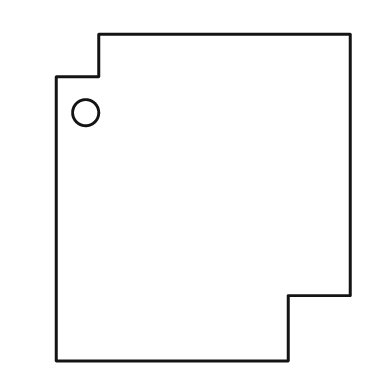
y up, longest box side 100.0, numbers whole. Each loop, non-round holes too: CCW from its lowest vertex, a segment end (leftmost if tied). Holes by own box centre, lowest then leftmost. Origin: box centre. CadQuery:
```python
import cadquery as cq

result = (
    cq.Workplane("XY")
    .moveTo(-45.0, -50.0)
    .lineTo(26.0, -50.0)
    .lineTo(26.0, -30.0)
    .lineTo(45.0, -30.0)
    .lineTo(45.0, 50.0)
    .lineTo(-32.0, 50.0)
    .lineTo(-32.0, 37.0)
    .lineTo(-45.0, 37.0)
    .close()
    .moveTo(-36.0, 26.0)
    .circle(4.0)
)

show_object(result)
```